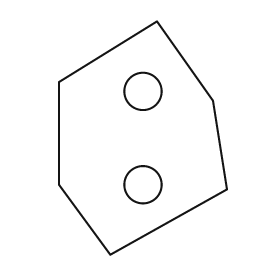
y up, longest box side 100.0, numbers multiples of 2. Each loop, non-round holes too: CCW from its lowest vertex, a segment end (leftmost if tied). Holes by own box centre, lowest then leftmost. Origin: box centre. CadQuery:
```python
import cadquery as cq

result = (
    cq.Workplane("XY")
    .moveTo(-14.0, -50.0)
    .lineTo(36.0, -22.0)
    .lineTo(30.0, 16.0)
    .lineTo(6.0, 50.0)
    .lineTo(-36.0, 24.0)
    .lineTo(-36.0, -20.0)
    .close()
    .moveTo(0.0, -20.0)
    .circle(8.0)
    .moveTo(0.0, 20.0)
    .circle(8.0)
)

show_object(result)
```